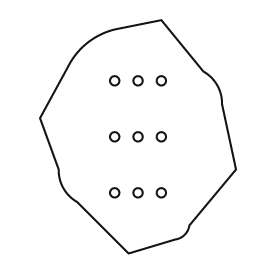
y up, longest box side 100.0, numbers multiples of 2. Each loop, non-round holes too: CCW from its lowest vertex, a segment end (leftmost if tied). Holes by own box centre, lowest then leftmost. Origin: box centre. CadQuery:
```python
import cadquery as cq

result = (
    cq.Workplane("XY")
    .moveTo(-4.0, -50.0)
    .lineTo(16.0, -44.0)
    .threePointArc((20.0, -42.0), (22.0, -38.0))
    .lineTo(42.0, -14.0)
    .lineTo(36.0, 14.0)
    .threePointArc((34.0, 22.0), (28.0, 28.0))
    .lineTo(10.0, 50.0)
    .lineTo(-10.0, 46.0)
    .threePointArc((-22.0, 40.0), (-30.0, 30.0))
    .lineTo(-42.0, 8.0)
    .lineTo(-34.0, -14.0)
    .threePointArc((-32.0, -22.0), (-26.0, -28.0))
    .close()
    .moveTo(-10.0, -24.0)
    .circle(2.0)
    .moveTo(0.0, -24.0)
    .circle(2.0)
    .moveTo(10.0, -24.0)
    .circle(2.0)
    .moveTo(-10.0, 0.0)
    .circle(2.0)
    .moveTo(0.0, 0.0)
    .circle(2.0)
    .moveTo(10.0, 0.0)
    .circle(2.0)
    .moveTo(-10.0, 24.0)
    .circle(2.0)
    .moveTo(0.0, 24.0)
    .circle(2.0)
    .moveTo(10.0, 24.0)
    .circle(2.0)
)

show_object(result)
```